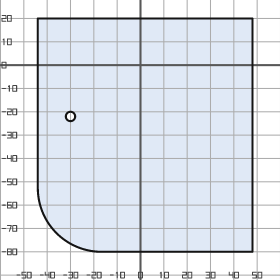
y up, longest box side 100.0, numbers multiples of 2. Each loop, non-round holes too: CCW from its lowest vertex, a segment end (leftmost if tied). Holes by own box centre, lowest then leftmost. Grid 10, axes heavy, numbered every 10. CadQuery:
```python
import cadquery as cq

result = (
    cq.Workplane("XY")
    .moveTo(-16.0, -80.0)
    .lineTo(48.0, -80.0)
    .lineTo(48.0, 20.0)
    .lineTo(-44.0, 20.0)
    .lineTo(-44.0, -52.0)
    .threePointArc((-36.0, -72.0), (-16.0, -80.0))
    .close()
    .moveTo(-30.0, -22.0)
    .circle(2.0)
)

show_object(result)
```